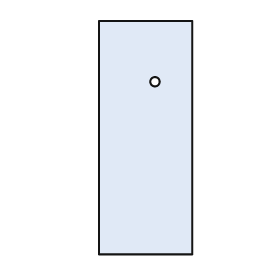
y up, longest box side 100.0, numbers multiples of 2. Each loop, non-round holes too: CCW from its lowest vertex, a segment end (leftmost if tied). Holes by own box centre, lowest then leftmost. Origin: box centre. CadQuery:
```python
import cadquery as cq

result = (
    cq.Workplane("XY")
    .moveTo(-20.0, -50.0)
    .lineTo(20.0, -50.0)
    .lineTo(20.0, 50.0)
    .lineTo(-20.0, 50.0)
    .close()
    .moveTo(4.0, 24.0)
    .circle(2.0)
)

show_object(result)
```